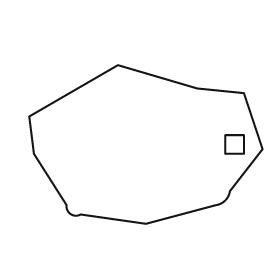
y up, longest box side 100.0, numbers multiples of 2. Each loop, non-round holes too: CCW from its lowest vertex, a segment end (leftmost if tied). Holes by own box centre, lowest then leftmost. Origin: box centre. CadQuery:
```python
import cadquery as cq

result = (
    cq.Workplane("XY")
    .moveTo(0.0, -34.0)
    .lineTo(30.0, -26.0)
    .threePointArc((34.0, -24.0), (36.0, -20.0))
    .lineTo(50.0, -2.0)
    .lineTo(42.0, 22.0)
    .lineTo(22.0, 24.0)
    .lineTo(-12.0, 34.0)
    .lineTo(-50.0, 12.0)
    .lineTo(-48.0, -4.0)
    .lineTo(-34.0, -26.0)
    .threePointArc((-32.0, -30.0), (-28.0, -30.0))
    .close()
    .moveTo(34.0, -4.0)
    .lineTo(42.0, -4.0)
    .lineTo(42.0, 4.0)
    .lineTo(34.0, 4.0)
    .close()
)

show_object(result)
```